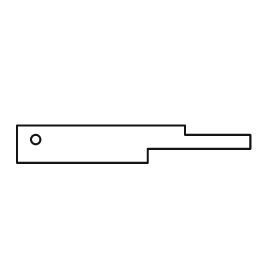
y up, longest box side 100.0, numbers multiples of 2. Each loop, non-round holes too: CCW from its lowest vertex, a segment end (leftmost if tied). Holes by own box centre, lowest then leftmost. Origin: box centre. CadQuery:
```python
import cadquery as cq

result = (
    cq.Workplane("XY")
    .moveTo(-50.0, -8.0)
    .lineTo(6.0, -8.0)
    .lineTo(6.0, -2.0)
    .lineTo(50.0, -2.0)
    .lineTo(50.0, 4.0)
    .lineTo(22.0, 4.0)
    .lineTo(22.0, 8.0)
    .lineTo(-50.0, 8.0)
    .close()
    .moveTo(-42.0, 2.0)
    .circle(2.0)
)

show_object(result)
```